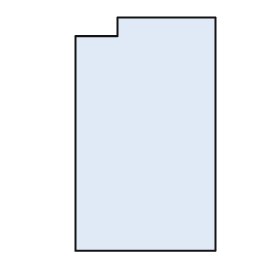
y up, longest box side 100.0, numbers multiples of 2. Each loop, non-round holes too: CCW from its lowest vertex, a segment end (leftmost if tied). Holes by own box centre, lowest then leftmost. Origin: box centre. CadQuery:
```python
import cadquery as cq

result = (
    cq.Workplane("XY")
    .moveTo(-30.0, -50.0)
    .lineTo(30.0, -50.0)
    .lineTo(30.0, 50.0)
    .lineTo(-12.0, 50.0)
    .lineTo(-12.0, 42.0)
    .lineTo(-30.0, 42.0)
    .close()
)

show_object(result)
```